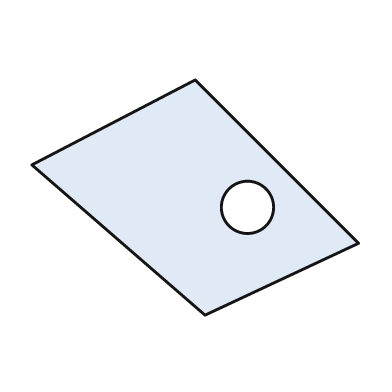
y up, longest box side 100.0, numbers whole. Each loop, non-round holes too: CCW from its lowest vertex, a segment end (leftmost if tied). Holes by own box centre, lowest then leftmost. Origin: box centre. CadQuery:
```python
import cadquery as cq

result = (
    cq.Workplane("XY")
    .moveTo(3.0, -36.0)
    .lineTo(50.0, -14.0)
    .lineTo(0.0, 36.0)
    .lineTo(-50.0, 10.0)
    .close()
    .moveTo(16.0, -3.0)
    .circle(8.0)
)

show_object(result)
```